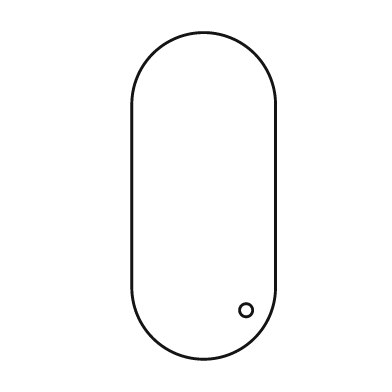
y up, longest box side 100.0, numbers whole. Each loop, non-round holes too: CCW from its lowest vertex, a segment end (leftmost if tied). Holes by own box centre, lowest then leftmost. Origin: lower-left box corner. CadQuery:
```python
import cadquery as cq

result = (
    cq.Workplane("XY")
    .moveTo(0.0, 22.0)
    .threePointArc((22.0, 0.0), (44.0, 22.0))
    .lineTo(44.0, 78.0)
    .threePointArc((22.0, 100.0), (0.0, 78.0))
    .close()
    .moveTo(35.0, 15.0)
    .circle(2.0)
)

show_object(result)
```